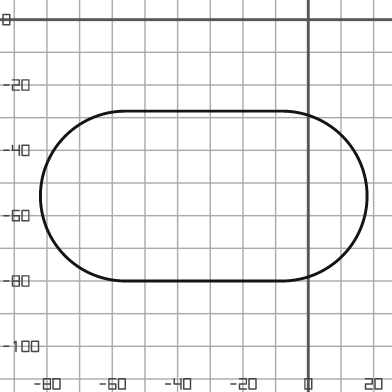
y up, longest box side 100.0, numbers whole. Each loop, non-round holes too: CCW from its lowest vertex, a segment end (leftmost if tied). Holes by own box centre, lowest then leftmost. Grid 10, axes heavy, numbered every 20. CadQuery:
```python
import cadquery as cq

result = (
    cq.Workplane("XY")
    .moveTo(-56.0, -80.0)
    .lineTo(-8.0, -80.0)
    .threePointArc((18.0, -54.0), (-8.0, -28.0))
    .lineTo(-56.0, -28.0)
    .threePointArc((-82.0, -54.0), (-56.0, -80.0))
    .close()
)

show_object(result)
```